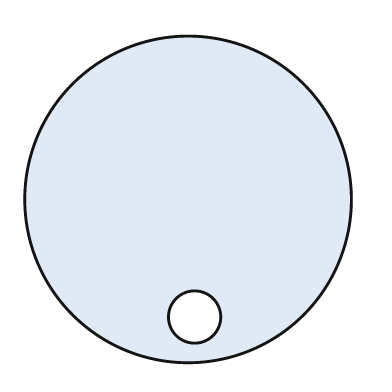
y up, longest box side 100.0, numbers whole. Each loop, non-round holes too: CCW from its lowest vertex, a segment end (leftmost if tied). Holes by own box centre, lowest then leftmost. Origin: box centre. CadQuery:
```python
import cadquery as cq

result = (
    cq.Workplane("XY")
    .moveTo(0.0, 0.0)
    .circle(50.0)
    .moveTo(2.0, -36.0)
    .circle(8.0)
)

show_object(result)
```